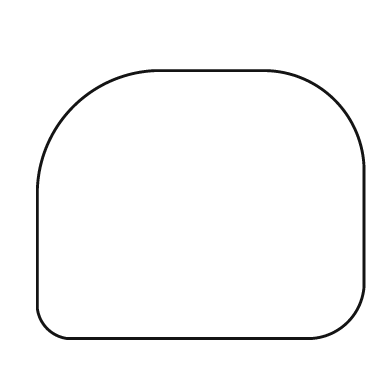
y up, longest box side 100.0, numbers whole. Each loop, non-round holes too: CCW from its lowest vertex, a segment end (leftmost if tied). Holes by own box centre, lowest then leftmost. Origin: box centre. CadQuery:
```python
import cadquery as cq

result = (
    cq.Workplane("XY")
    .moveTo(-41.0, -41.0)
    .lineTo(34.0, -41.0)
    .threePointArc((45.0, -36.0), (50.0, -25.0))
    .lineTo(50.0, 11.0)
    .threePointArc((41.0, 32.0), (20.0, 41.0))
    .lineTo(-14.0, 41.0)
    .threePointArc((-39.0, 30.0), (-50.0, 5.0))
    .lineTo(-50.0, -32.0)
    .threePointArc((-47.0, -38.0), (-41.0, -41.0))
    .close()
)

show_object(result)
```